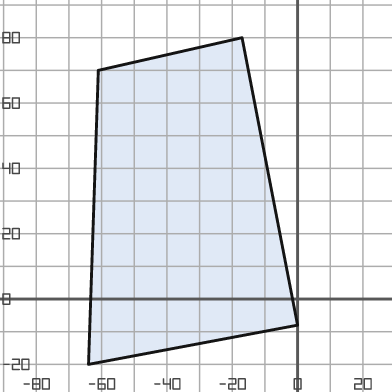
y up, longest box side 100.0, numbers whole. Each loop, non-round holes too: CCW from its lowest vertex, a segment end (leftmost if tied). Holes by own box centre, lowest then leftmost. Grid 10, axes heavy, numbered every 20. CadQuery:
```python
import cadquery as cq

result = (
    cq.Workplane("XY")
    .moveTo(-64.0, -20.0)
    .lineTo(0.0, -8.0)
    .lineTo(-17.0, 80.0)
    .lineTo(-61.0, 70.0)
    .close()
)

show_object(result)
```